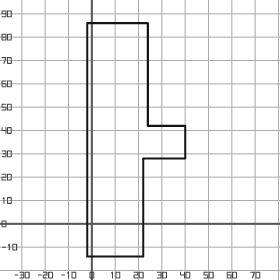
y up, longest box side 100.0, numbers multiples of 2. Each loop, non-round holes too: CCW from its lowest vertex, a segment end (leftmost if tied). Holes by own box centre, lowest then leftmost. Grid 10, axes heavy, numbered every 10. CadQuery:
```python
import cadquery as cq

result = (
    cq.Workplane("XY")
    .moveTo(-2.0, -14.0)
    .lineTo(22.0, -14.0)
    .lineTo(22.0, 28.0)
    .lineTo(40.0, 28.0)
    .lineTo(40.0, 42.0)
    .lineTo(24.0, 42.0)
    .lineTo(24.0, 86.0)
    .lineTo(-2.0, 86.0)
    .close()
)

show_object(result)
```